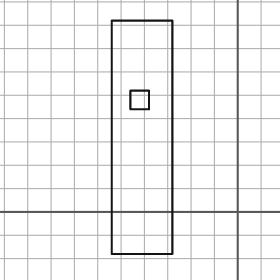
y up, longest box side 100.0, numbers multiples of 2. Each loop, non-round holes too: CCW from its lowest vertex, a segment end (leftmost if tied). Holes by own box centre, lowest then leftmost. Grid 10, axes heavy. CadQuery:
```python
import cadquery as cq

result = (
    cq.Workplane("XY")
    .moveTo(-54.0, -18.0)
    .lineTo(-28.0, -18.0)
    .lineTo(-28.0, 82.0)
    .lineTo(-54.0, 82.0)
    .close()
    .moveTo(-46.0, 44.0)
    .lineTo(-38.0, 44.0)
    .lineTo(-38.0, 52.0)
    .lineTo(-46.0, 52.0)
    .close()
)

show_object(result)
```